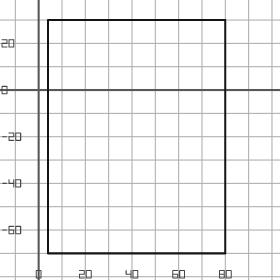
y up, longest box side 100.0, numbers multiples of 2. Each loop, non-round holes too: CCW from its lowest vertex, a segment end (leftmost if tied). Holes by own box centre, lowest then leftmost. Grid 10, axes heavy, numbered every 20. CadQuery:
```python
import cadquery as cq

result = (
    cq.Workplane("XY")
    .moveTo(4.0, -70.0)
    .lineTo(80.0, -70.0)
    .lineTo(80.0, 30.0)
    .lineTo(4.0, 30.0)
    .close()
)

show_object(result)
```